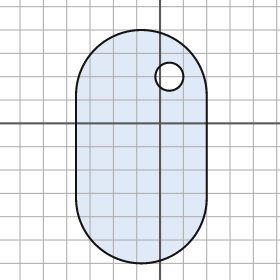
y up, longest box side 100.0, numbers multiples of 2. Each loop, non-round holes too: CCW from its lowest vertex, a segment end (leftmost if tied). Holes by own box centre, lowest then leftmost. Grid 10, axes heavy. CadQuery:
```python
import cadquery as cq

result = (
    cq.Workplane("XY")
    .moveTo(-36.0, -32.0)
    .threePointArc((-8.0, -60.0), (20.0, -32.0))
    .lineTo(20.0, 12.0)
    .threePointArc((-8.0, 40.0), (-36.0, 12.0))
    .close()
    .moveTo(4.0, 20.0)
    .circle(6.0)
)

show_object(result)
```